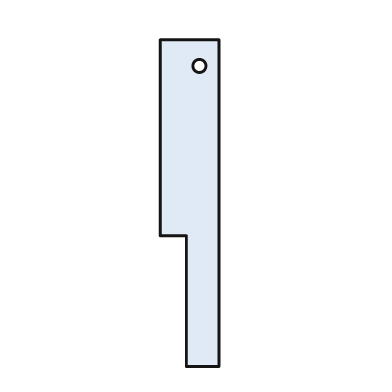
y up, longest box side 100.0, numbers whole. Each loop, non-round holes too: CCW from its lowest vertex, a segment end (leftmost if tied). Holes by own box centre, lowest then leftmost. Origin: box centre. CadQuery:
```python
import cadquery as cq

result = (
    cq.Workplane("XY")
    .moveTo(-1.0, -50.0)
    .lineTo(9.0, -50.0)
    .lineTo(9.0, 50.0)
    .lineTo(-9.0, 50.0)
    .lineTo(-9.0, -10.0)
    .lineTo(-1.0, -10.0)
    .close()
    .moveTo(3.0, 42.0)
    .circle(2.0)
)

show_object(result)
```